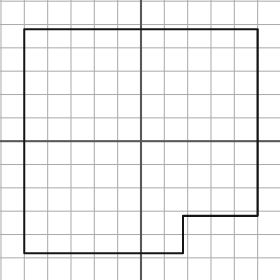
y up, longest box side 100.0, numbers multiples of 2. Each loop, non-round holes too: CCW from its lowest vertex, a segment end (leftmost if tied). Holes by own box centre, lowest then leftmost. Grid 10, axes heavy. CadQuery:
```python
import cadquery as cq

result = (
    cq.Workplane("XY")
    .moveTo(-50.0, -48.0)
    .lineTo(18.0, -48.0)
    .lineTo(18.0, -32.0)
    .lineTo(50.0, -32.0)
    .lineTo(50.0, 48.0)
    .lineTo(-50.0, 48.0)
    .close()
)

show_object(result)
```